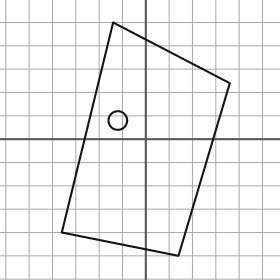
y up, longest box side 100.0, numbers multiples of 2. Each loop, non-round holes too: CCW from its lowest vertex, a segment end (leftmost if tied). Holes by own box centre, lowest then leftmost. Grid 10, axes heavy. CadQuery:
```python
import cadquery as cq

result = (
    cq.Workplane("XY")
    .moveTo(14.0, -50.0)
    .lineTo(36.0, 24.0)
    .lineTo(-14.0, 50.0)
    .lineTo(-36.0, -40.0)
    .close()
    .moveTo(-12.0, 8.0)
    .circle(4.0)
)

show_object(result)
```